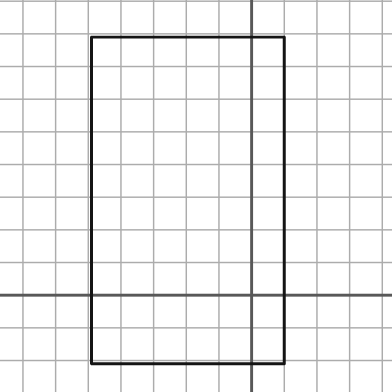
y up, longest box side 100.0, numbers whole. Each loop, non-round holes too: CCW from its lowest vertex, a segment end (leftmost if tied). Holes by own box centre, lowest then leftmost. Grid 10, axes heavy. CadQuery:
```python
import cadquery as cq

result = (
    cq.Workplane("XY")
    .moveTo(-49.0, -21.0)
    .lineTo(10.0, -21.0)
    .lineTo(10.0, 79.0)
    .lineTo(-49.0, 79.0)
    .close()
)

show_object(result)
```